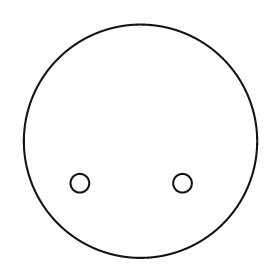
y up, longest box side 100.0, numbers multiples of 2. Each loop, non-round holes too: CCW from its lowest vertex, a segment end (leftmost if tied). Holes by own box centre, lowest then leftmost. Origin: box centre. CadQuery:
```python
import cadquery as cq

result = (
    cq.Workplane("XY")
    .moveTo(0.0, 0.0)
    .circle(50.0)
    .moveTo(-26.0, -18.0)
    .circle(4.0)
    .moveTo(18.0, -18.0)
    .circle(4.0)
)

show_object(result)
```